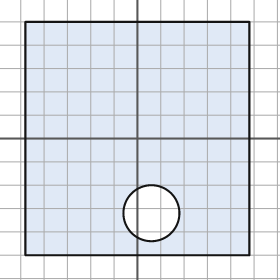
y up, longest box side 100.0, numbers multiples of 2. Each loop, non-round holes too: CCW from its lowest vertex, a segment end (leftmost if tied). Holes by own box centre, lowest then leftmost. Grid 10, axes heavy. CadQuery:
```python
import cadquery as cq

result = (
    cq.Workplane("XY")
    .moveTo(-48.0, -50.0)
    .lineTo(48.0, -50.0)
    .lineTo(48.0, 50.0)
    .lineTo(-48.0, 50.0)
    .close()
    .moveTo(6.0, -32.0)
    .circle(12.0)
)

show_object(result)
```